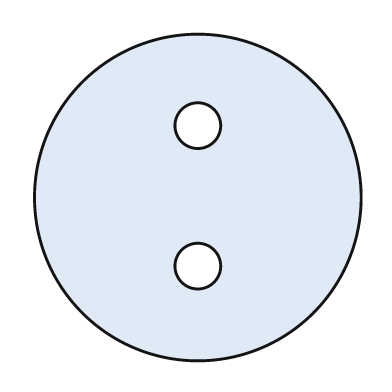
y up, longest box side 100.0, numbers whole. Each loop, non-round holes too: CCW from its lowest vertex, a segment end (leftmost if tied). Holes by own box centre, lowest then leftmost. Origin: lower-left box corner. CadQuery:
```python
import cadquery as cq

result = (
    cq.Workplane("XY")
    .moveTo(50.0, 50.0)
    .circle(50.0)
    .moveTo(50.0, 29.0)
    .circle(7.0)
    .moveTo(50.0, 72.0)
    .circle(7.0)
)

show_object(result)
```